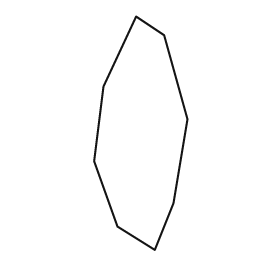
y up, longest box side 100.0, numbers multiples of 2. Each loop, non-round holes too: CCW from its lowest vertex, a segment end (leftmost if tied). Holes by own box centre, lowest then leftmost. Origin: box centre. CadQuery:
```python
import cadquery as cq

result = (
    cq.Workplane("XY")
    .moveTo(6.0, -50.0)
    .lineTo(14.0, -30.0)
    .lineTo(20.0, 6.0)
    .lineTo(10.0, 42.0)
    .lineTo(-2.0, 50.0)
    .lineTo(-16.0, 20.0)
    .lineTo(-20.0, -12.0)
    .lineTo(-10.0, -40.0)
    .close()
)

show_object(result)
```